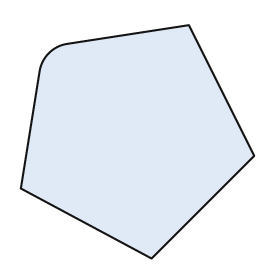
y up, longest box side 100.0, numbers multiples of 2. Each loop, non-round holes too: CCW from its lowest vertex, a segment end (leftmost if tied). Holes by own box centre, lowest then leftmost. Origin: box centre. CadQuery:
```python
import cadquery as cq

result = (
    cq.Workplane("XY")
    .moveTo(6.0, -50.0)
    .lineTo(50.0, -6.0)
    .lineTo(22.0, 50.0)
    .lineTo(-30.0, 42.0)
    .threePointArc((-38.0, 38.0), (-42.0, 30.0))
    .lineTo(-50.0, -20.0)
    .close()
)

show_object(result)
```